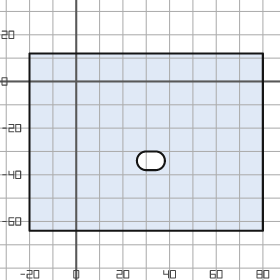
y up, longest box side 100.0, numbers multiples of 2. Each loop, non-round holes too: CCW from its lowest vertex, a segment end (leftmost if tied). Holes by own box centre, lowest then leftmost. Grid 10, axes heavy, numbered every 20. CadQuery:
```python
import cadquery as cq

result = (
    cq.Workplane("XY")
    .moveTo(-20.0, -64.0)
    .lineTo(80.0, -64.0)
    .lineTo(80.0, 12.0)
    .lineTo(-20.0, 12.0)
    .close()
    .moveTo(30.0, -38.0)
    .lineTo(34.0, -38.0)
    .threePointArc((38.0, -34.0), (34.0, -30.0))
    .lineTo(30.0, -30.0)
    .threePointArc((26.0, -34.0), (30.0, -38.0))
    .close()
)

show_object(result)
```